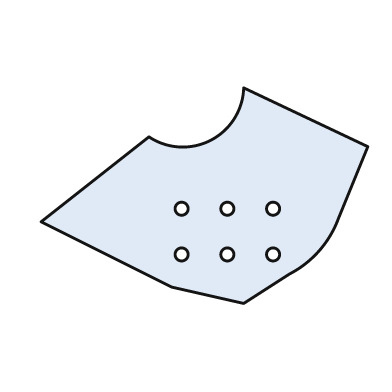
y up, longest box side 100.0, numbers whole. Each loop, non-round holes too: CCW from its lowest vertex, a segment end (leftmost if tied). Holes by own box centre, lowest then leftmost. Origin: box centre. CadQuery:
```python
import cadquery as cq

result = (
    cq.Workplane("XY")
    .moveTo(12.0, -33.0)
    .lineTo(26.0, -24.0)
    .threePointArc((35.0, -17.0), (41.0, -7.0))
    .lineTo(50.0, 15.0)
    .lineTo(12.0, 33.0)
    .threePointArc((2.0, 17.0), (-17.0, 18.0))
    .lineTo(-50.0, -8.0)
    .lineTo(-10.0, -28.0)
    .close()
    .moveTo(-7.0, -18.0)
    .circle(2.0)
    .moveTo(7.0, -18.0)
    .circle(2.0)
    .moveTo(21.0, -18.0)
    .circle(2.0)
    .moveTo(-7.0, -4.0)
    .circle(2.0)
    .moveTo(7.0, -4.0)
    .circle(2.0)
    .moveTo(21.0, -4.0)
    .circle(2.0)
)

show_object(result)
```